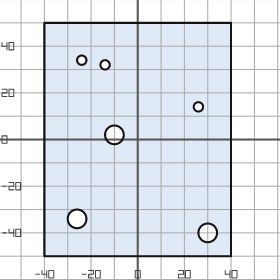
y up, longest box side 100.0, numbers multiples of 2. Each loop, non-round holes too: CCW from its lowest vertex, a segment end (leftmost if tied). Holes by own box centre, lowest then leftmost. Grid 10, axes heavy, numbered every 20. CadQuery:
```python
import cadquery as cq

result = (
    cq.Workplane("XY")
    .moveTo(-40.0, -50.0)
    .lineTo(40.0, -50.0)
    .lineTo(40.0, 50.0)
    .lineTo(-40.0, 50.0)
    .close()
    .moveTo(30.0, -40.0)
    .circle(4.0)
    .moveTo(-26.0, -34.0)
    .circle(4.0)
    .moveTo(-10.0, 2.0)
    .circle(4.0)
    .moveTo(26.0, 14.0)
    .circle(2.0)
    .moveTo(-14.0, 32.0)
    .circle(2.0)
    .moveTo(-24.0, 34.0)
    .circle(2.0)
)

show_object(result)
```